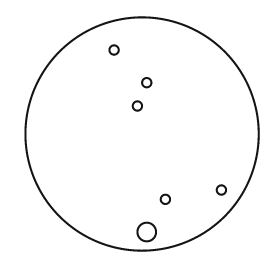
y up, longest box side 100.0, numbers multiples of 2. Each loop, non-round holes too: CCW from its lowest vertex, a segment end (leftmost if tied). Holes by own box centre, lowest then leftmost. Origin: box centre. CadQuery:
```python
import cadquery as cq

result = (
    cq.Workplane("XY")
    .moveTo(0.0, 0.0)
    .circle(50.0)
    .moveTo(2.0, -42.0)
    .circle(4.0)
    .moveTo(10.0, -28.0)
    .circle(2.0)
    .moveTo(34.0, -24.0)
    .circle(2.0)
    .moveTo(-2.0, 12.0)
    .circle(2.0)
    .moveTo(2.0, 22.0)
    .circle(2.0)
    .moveTo(-12.0, 36.0)
    .circle(2.0)
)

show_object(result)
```